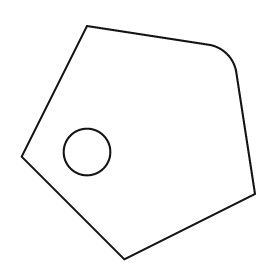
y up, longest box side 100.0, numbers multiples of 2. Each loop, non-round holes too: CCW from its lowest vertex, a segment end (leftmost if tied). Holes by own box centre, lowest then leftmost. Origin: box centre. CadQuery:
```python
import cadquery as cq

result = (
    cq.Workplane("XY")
    .moveTo(-6.0, -50.0)
    .lineTo(50.0, -22.0)
    .lineTo(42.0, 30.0)
    .threePointArc((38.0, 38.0), (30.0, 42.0))
    .lineTo(-22.0, 50.0)
    .lineTo(-50.0, -6.0)
    .close()
    .moveTo(-22.0, -4.0)
    .circle(10.0)
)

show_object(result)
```